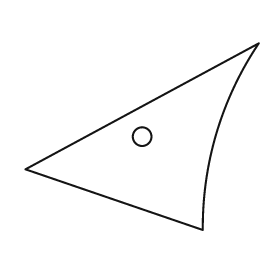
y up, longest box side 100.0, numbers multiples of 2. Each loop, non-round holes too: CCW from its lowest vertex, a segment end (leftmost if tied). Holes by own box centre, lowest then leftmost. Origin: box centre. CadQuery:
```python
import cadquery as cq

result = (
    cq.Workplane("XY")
    .moveTo(26.0, -40.0)
    .threePointArc((32.0, 2.0), (50.0, 40.0))
    .lineTo(-50.0, -14.0)
    .close()
    .moveTo(0.0, 0.0)
    .circle(4.0)
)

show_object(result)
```